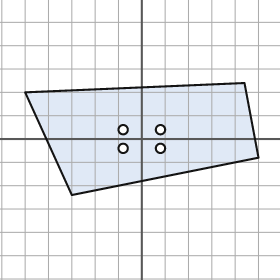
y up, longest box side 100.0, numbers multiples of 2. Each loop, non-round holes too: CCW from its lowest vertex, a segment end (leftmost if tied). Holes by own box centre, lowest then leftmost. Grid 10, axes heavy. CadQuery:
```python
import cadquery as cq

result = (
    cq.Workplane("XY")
    .moveTo(-30.0, -24.0)
    .lineTo(50.0, -8.0)
    .lineTo(44.0, 24.0)
    .lineTo(-50.0, 20.0)
    .close()
    .moveTo(-8.0, -4.0)
    .circle(2.0)
    .moveTo(8.0, -4.0)
    .circle(2.0)
    .moveTo(-8.0, 4.0)
    .circle(2.0)
    .moveTo(8.0, 4.0)
    .circle(2.0)
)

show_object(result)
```